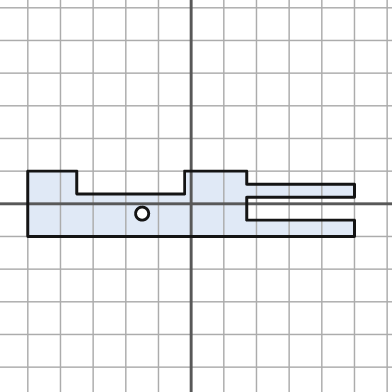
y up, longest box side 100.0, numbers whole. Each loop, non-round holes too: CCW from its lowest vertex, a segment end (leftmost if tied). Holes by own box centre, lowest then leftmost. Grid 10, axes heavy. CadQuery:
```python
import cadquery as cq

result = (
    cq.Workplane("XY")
    .moveTo(-50.0, -10.0)
    .lineTo(50.0, -10.0)
    .lineTo(50.0, -5.0)
    .lineTo(17.0, -5.0)
    .lineTo(17.0, 2.0)
    .lineTo(50.0, 2.0)
    .lineTo(50.0, 6.0)
    .lineTo(17.0, 6.0)
    .lineTo(17.0, 10.0)
    .lineTo(-2.0, 10.0)
    .lineTo(-2.0, 3.0)
    .lineTo(-35.0, 3.0)
    .lineTo(-35.0, 10.0)
    .lineTo(-50.0, 10.0)
    .close()
    .moveTo(-15.0, -3.0)
    .circle(2.0)
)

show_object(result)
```